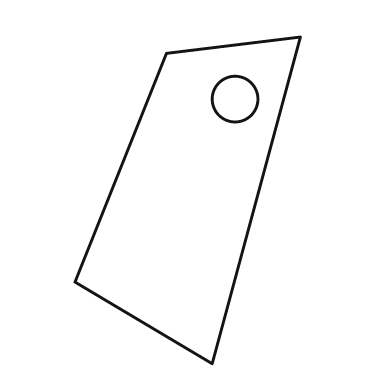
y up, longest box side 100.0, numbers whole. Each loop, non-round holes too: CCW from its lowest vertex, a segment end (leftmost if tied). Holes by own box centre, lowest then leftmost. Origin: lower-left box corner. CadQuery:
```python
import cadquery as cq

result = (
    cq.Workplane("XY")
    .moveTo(42.0, 0.0)
    .lineTo(69.0, 100.0)
    .lineTo(28.0, 95.0)
    .lineTo(0.0, 25.0)
    .close()
    .moveTo(49.0, 81.0)
    .circle(7.0)
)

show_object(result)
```